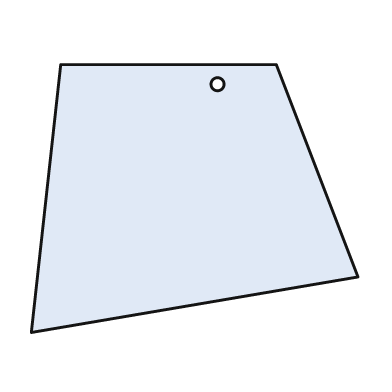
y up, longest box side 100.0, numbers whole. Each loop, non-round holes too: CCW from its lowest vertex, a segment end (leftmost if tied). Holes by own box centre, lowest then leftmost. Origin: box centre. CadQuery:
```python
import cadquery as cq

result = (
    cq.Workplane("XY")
    .moveTo(-50.0, -41.0)
    .lineTo(50.0, -24.0)
    .lineTo(25.0, 41.0)
    .lineTo(-41.0, 41.0)
    .close()
    .moveTo(7.0, 35.0)
    .circle(2.0)
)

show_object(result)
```